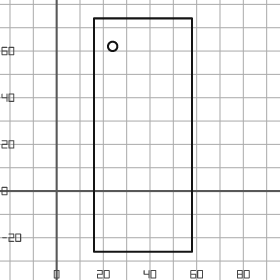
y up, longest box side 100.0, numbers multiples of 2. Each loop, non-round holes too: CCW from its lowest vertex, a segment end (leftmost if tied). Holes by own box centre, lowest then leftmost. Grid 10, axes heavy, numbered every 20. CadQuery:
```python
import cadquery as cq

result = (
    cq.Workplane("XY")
    .moveTo(16.0, -26.0)
    .lineTo(58.0, -26.0)
    .lineTo(58.0, 74.0)
    .lineTo(16.0, 74.0)
    .close()
    .moveTo(24.0, 62.0)
    .circle(2.0)
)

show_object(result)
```